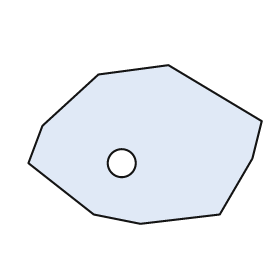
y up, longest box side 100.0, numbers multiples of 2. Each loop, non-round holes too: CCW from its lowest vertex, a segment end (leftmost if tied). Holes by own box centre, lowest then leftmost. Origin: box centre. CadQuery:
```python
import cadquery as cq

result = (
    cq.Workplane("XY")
    .moveTo(-2.0, -34.0)
    .lineTo(32.0, -30.0)
    .lineTo(46.0, -6.0)
    .lineTo(50.0, 10.0)
    .lineTo(10.0, 34.0)
    .lineTo(-20.0, 30.0)
    .lineTo(-44.0, 8.0)
    .lineTo(-50.0, -8.0)
    .lineTo(-22.0, -30.0)
    .close()
    .moveTo(-10.0, -8.0)
    .circle(6.0)
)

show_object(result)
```